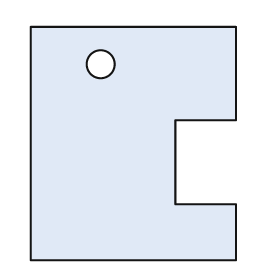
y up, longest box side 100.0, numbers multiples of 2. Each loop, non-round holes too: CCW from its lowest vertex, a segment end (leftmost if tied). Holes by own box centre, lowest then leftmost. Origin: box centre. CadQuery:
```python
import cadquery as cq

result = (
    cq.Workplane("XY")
    .moveTo(-44.0, -50.0)
    .lineTo(44.0, -50.0)
    .lineTo(44.0, -26.0)
    .lineTo(18.0, -26.0)
    .lineTo(18.0, 10.0)
    .lineTo(44.0, 10.0)
    .lineTo(44.0, 50.0)
    .lineTo(-44.0, 50.0)
    .close()
    .moveTo(-14.0, 34.0)
    .circle(6.0)
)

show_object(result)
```